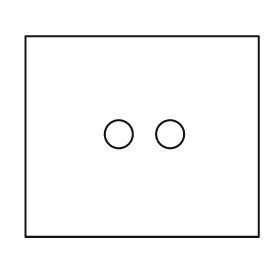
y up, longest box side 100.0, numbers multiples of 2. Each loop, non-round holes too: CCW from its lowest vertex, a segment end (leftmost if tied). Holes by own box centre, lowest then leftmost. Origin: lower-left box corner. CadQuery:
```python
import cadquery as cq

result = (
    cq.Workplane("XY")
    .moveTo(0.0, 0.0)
    .lineTo(100.0, 0.0)
    .lineTo(100.0, 86.0)
    .lineTo(0.0, 86.0)
    .close()
    .moveTo(40.0, 44.0)
    .circle(6.0)
    .moveTo(62.0, 44.0)
    .circle(6.0)
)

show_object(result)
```